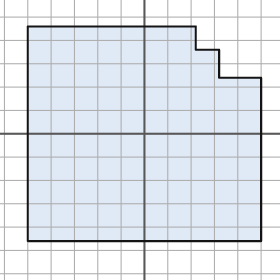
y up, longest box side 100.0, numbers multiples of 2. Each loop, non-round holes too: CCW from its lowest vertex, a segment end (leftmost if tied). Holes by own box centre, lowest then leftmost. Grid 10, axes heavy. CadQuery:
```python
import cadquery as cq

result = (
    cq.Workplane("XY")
    .moveTo(-50.0, -46.0)
    .lineTo(50.0, -46.0)
    .lineTo(50.0, 24.0)
    .lineTo(32.0, 24.0)
    .lineTo(32.0, 36.0)
    .lineTo(22.0, 36.0)
    .lineTo(22.0, 46.0)
    .lineTo(-50.0, 46.0)
    .close()
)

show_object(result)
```